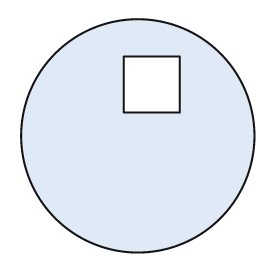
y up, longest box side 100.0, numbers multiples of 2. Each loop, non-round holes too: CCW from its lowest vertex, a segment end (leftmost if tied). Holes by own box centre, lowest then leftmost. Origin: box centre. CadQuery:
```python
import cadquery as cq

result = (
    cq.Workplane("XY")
    .moveTo(0.0, 0.0)
    .circle(50.0)
    .moveTo(-6.0, 10.0)
    .lineTo(18.0, 10.0)
    .lineTo(18.0, 34.0)
    .lineTo(-6.0, 34.0)
    .close()
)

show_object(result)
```